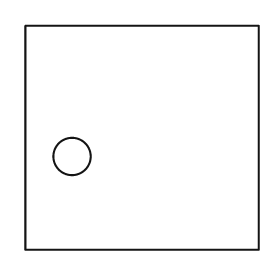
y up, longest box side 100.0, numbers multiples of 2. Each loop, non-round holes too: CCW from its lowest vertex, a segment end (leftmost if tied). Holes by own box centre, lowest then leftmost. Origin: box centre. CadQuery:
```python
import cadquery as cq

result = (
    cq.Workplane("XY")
    .moveTo(-50.0, -48.0)
    .lineTo(50.0, -48.0)
    .lineTo(50.0, 48.0)
    .lineTo(-50.0, 48.0)
    .close()
    .moveTo(-30.0, -8.0)
    .circle(8.0)
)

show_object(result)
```